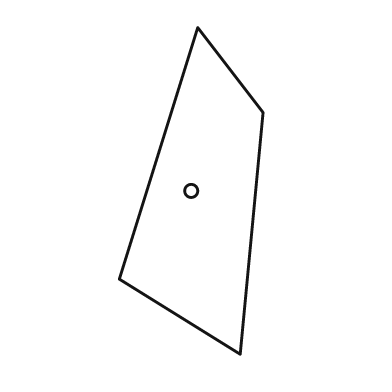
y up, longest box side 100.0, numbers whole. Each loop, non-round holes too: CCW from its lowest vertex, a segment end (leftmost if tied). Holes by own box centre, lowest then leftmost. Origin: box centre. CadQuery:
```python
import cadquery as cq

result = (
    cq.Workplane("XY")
    .moveTo(15.0, -50.0)
    .lineTo(22.0, 24.0)
    .lineTo(2.0, 50.0)
    .lineTo(-22.0, -27.0)
    .close()
    .moveTo(0.0, 0.0)
    .circle(2.0)
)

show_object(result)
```